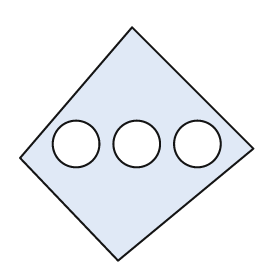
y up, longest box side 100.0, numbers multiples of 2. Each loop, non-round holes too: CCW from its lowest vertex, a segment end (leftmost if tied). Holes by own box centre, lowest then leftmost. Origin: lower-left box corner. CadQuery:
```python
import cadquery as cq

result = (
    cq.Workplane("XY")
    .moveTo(42.0, 0.0)
    .lineTo(100.0, 48.0)
    .lineTo(48.0, 100.0)
    .lineTo(0.0, 44.0)
    .close()
    .moveTo(24.0, 50.0)
    .circle(10.0)
    .moveTo(50.0, 50.0)
    .circle(10.0)
    .moveTo(76.0, 50.0)
    .circle(10.0)
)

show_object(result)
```